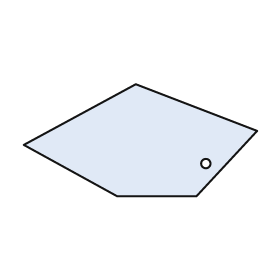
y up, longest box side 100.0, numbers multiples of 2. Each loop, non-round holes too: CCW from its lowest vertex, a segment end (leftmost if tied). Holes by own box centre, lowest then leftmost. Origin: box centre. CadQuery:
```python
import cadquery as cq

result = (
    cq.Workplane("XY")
    .moveTo(-10.0, -24.0)
    .lineTo(24.0, -24.0)
    .lineTo(50.0, 4.0)
    .lineTo(-2.0, 24.0)
    .lineTo(-50.0, -2.0)
    .close()
    .moveTo(28.0, -10.0)
    .circle(2.0)
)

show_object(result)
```